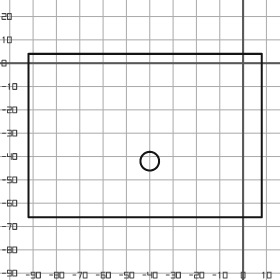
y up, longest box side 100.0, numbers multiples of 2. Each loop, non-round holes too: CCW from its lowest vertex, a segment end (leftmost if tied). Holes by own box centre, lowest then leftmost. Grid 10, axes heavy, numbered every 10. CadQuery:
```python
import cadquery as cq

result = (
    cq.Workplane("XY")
    .moveTo(-92.0, -66.0)
    .lineTo(8.0, -66.0)
    .lineTo(8.0, 4.0)
    .lineTo(-92.0, 4.0)
    .close()
    .moveTo(-40.0, -42.0)
    .circle(4.0)
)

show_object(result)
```